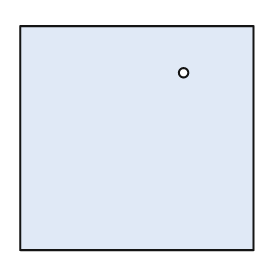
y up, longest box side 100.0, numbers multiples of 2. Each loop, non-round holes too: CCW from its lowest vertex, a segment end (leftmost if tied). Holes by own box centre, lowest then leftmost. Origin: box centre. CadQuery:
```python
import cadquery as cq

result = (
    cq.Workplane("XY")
    .moveTo(-50.0, -48.0)
    .lineTo(50.0, -48.0)
    .lineTo(50.0, 48.0)
    .lineTo(-50.0, 48.0)
    .close()
    .moveTo(20.0, 28.0)
    .circle(2.0)
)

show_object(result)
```